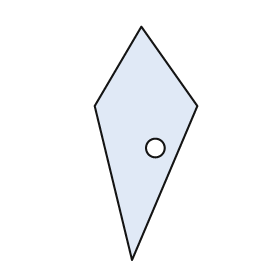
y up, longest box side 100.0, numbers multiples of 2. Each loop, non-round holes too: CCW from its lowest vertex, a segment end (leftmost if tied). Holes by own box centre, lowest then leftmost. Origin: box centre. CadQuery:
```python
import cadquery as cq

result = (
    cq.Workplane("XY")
    .moveTo(-6.0, -50.0)
    .lineTo(22.0, 16.0)
    .lineTo(-2.0, 50.0)
    .lineTo(-22.0, 16.0)
    .close()
    .moveTo(4.0, -2.0)
    .circle(4.0)
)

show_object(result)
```